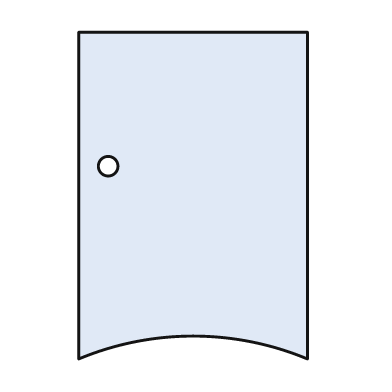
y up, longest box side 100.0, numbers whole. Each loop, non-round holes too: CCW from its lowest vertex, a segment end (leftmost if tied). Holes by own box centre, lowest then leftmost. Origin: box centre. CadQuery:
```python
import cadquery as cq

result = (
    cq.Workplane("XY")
    .moveTo(-35.0, -50.0)
    .threePointArc((0.0, -43.0), (35.0, -50.0))
    .lineTo(35.0, 50.0)
    .lineTo(-35.0, 50.0)
    .close()
    .moveTo(-26.0, 9.0)
    .circle(3.0)
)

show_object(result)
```